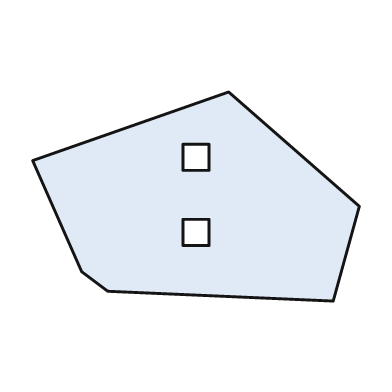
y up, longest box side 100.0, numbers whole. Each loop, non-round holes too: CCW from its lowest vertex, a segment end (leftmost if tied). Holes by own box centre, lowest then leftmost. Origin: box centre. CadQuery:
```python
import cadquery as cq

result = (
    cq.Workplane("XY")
    .moveTo(42.0, -32.0)
    .lineTo(50.0, -3.0)
    .lineTo(10.0, 32.0)
    .lineTo(-50.0, 11.0)
    .lineTo(-35.0, -23.0)
    .lineTo(-27.0, -29.0)
    .close()
    .moveTo(-4.0, -15.0)
    .lineTo(4.0, -15.0)
    .lineTo(4.0, -7.0)
    .lineTo(-4.0, -7.0)
    .close()
    .moveTo(-4.0, 8.0)
    .lineTo(4.0, 8.0)
    .lineTo(4.0, 16.0)
    .lineTo(-4.0, 16.0)
    .close()
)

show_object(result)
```